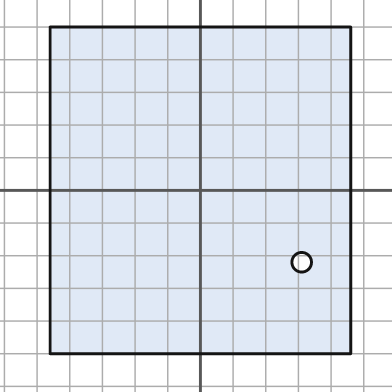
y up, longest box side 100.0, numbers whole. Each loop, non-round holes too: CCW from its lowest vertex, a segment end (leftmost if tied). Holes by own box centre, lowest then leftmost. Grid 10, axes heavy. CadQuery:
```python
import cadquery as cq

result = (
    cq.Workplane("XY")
    .moveTo(-46.0, -50.0)
    .lineTo(46.0, -50.0)
    .lineTo(46.0, 50.0)
    .lineTo(-46.0, 50.0)
    .close()
    .moveTo(31.0, -22.0)
    .circle(3.0)
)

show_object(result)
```